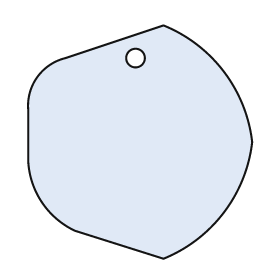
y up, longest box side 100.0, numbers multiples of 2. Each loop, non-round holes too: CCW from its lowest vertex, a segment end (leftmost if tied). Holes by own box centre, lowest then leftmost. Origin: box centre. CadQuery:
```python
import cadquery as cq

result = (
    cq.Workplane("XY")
    .moveTo(10.0, -50.0)
    .threePointArc((36.0, -30.0), (48.0, 0.0))
    .threePointArc((36.0, 30.0), (10.0, 50.0))
    .lineTo(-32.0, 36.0)
    .threePointArc((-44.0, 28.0), (-48.0, 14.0))
    .lineTo(-48.0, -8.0)
    .threePointArc((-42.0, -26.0), (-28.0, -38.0))
    .close()
    .moveTo(-2.0, 36.0)
    .circle(4.0)
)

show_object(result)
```